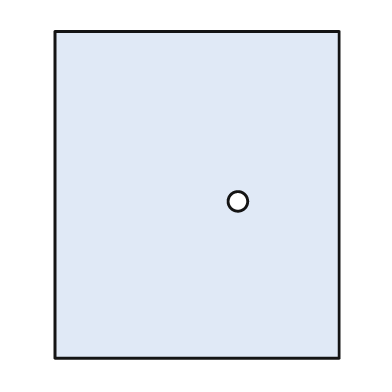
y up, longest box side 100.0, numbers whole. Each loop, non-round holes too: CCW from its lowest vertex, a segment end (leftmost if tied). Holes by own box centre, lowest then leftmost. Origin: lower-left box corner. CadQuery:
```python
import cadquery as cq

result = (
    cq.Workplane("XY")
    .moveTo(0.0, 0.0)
    .lineTo(87.0, 0.0)
    .lineTo(87.0, 100.0)
    .lineTo(0.0, 100.0)
    .close()
    .moveTo(56.0, 48.0)
    .circle(3.0)
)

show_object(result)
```